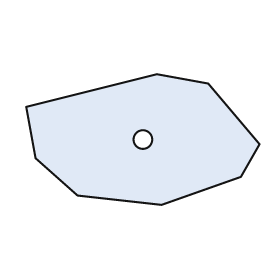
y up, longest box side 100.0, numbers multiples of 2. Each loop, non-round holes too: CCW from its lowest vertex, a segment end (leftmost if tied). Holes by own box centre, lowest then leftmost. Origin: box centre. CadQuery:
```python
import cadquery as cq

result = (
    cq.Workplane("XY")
    .moveTo(8.0, -28.0)
    .lineTo(42.0, -16.0)
    .lineTo(50.0, -2.0)
    .lineTo(28.0, 24.0)
    .lineTo(6.0, 28.0)
    .lineTo(-50.0, 14.0)
    .lineTo(-46.0, -8.0)
    .lineTo(-28.0, -24.0)
    .close()
    .moveTo(0.0, 0.0)
    .circle(4.0)
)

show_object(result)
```